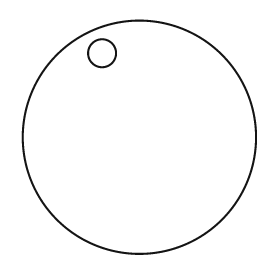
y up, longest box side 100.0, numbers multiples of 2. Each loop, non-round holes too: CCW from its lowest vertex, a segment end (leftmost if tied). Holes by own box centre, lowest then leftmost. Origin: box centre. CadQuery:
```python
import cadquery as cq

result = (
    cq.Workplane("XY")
    .moveTo(0.0, 0.0)
    .circle(50.0)
    .moveTo(-16.0, 36.0)
    .circle(6.0)
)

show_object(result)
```